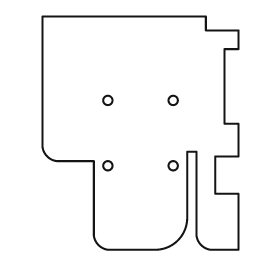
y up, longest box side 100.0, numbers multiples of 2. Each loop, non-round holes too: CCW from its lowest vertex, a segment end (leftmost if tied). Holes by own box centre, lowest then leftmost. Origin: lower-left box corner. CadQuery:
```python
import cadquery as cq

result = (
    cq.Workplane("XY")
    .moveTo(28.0, 0.0)
    .lineTo(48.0, 0.0)
    .threePointArc((58.0, 4.0), (62.0, 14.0))
    .lineTo(62.0, 42.0)
    .lineTo(66.0, 42.0)
    .lineTo(66.0, 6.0)
    .threePointArc((68.0, 2.0), (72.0, 0.0))
    .lineTo(84.0, 0.0)
    .lineTo(84.0, 24.0)
    .lineTo(74.0, 24.0)
    .lineTo(74.0, 40.0)
    .lineTo(84.0, 40.0)
    .lineTo(84.0, 54.0)
    .lineTo(78.0, 54.0)
    .lineTo(78.0, 86.0)
    .lineTo(84.0, 86.0)
    .lineTo(84.0, 94.0)
    .lineTo(70.0, 94.0)
    .lineTo(70.0, 100.0)
    .lineTo(0.0, 100.0)
    .lineTo(0.0, 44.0)
    .threePointArc((2.0, 40.0), (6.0, 38.0))
    .lineTo(22.0, 38.0)
    .lineTo(22.0, 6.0)
    .threePointArc((24.0, 2.0), (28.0, 0.0))
    .close()
    .moveTo(28.0, 36.0)
    .circle(2.0)
    .moveTo(56.0, 36.0)
    .circle(2.0)
    .moveTo(28.0, 64.0)
    .circle(2.0)
    .moveTo(56.0, 64.0)
    .circle(2.0)
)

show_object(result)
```